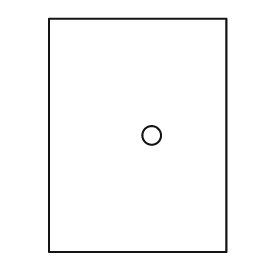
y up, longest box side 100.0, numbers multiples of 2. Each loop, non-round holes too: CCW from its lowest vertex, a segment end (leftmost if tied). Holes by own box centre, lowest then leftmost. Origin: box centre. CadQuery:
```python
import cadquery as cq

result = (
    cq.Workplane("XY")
    .moveTo(-38.0, -50.0)
    .lineTo(38.0, -50.0)
    .lineTo(38.0, 50.0)
    .lineTo(-38.0, 50.0)
    .close()
    .moveTo(6.0, 0.0)
    .circle(4.0)
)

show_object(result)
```